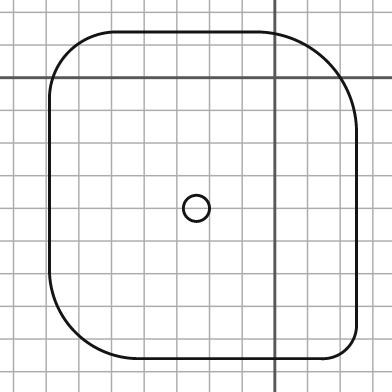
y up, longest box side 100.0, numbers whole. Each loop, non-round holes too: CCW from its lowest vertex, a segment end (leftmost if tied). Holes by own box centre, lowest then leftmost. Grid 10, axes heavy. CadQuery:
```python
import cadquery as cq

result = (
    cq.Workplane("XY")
    .moveTo(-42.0, -86.0)
    .lineTo(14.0, -86.0)
    .threePointArc((22.0, -83.0), (25.0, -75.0))
    .lineTo(25.0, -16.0)
    .threePointArc((16.0, 5.0), (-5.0, 14.0))
    .lineTo(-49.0, 14.0)
    .threePointArc((-63.0, 8.0), (-69.0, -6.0))
    .lineTo(-69.0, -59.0)
    .threePointArc((-61.0, -78.0), (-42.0, -86.0))
    .close()
    .moveTo(-24.0, -40.0)
    .circle(4.0)
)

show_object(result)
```